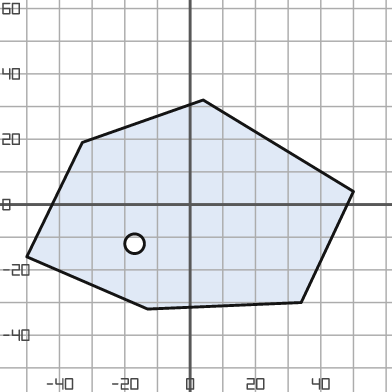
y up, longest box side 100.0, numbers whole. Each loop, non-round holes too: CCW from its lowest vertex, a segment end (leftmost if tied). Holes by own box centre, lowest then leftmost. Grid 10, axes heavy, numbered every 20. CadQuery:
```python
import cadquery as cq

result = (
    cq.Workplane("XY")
    .moveTo(-13.0, -32.0)
    .lineTo(34.0, -30.0)
    .lineTo(50.0, 4.0)
    .lineTo(4.0, 32.0)
    .lineTo(-33.0, 19.0)
    .lineTo(-50.0, -16.0)
    .close()
    .moveTo(-17.0, -12.0)
    .circle(3.0)
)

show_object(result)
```